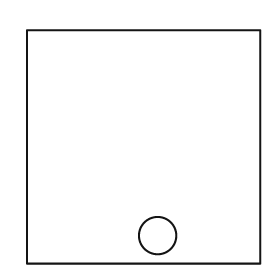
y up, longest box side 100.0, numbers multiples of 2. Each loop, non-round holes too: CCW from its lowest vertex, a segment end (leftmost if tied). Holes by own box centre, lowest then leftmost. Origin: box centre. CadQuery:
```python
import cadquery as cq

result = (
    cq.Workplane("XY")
    .moveTo(-50.0, -50.0)
    .lineTo(50.0, -50.0)
    .lineTo(50.0, 50.0)
    .lineTo(-50.0, 50.0)
    .close()
    .moveTo(6.0, -38.0)
    .circle(8.0)
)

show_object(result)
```